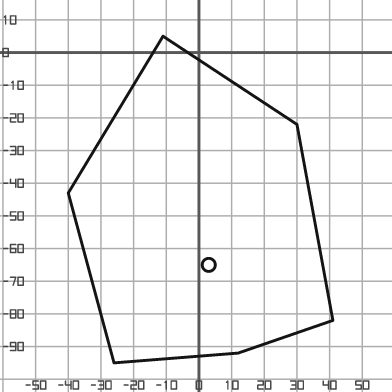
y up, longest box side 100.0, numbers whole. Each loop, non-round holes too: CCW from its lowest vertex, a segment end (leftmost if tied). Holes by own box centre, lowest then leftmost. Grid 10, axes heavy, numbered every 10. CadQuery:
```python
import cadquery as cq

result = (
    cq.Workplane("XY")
    .moveTo(-26.0, -95.0)
    .lineTo(12.0, -92.0)
    .lineTo(41.0, -82.0)
    .lineTo(30.0, -22.0)
    .lineTo(-11.0, 5.0)
    .lineTo(-40.0, -43.0)
    .close()
    .moveTo(3.0, -65.0)
    .circle(2.0)
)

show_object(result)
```